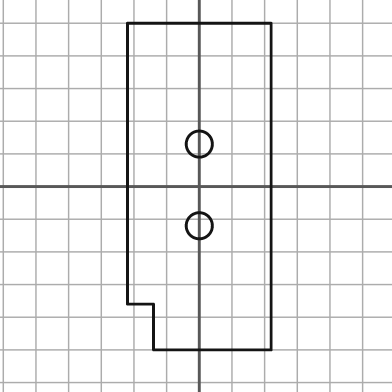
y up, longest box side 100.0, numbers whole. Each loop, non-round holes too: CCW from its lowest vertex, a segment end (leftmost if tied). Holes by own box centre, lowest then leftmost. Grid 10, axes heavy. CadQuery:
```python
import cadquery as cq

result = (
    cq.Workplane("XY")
    .moveTo(-14.0, -50.0)
    .lineTo(22.0, -50.0)
    .lineTo(22.0, 50.0)
    .lineTo(-22.0, 50.0)
    .lineTo(-22.0, -36.0)
    .lineTo(-14.0, -36.0)
    .close()
    .moveTo(0.0, -12.0)
    .circle(4.0)
    .moveTo(0.0, 13.0)
    .circle(4.0)
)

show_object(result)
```